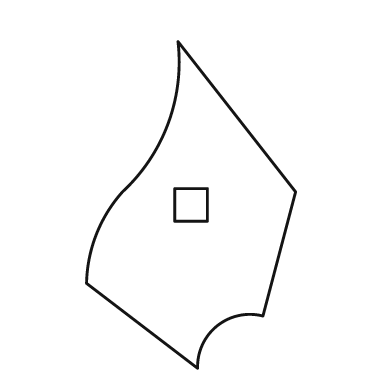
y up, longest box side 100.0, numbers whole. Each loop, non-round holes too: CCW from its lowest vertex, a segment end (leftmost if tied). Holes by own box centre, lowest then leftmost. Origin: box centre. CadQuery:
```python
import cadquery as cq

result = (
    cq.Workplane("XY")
    .moveTo(2.0, -50.0)
    .threePointArc((8.0, -37.0), (22.0, -34.0))
    .lineTo(32.0, 4.0)
    .lineTo(-4.0, 50.0)
    .threePointArc((-7.0, 25.0), (-21.0, 4.0))
    .threePointArc((-29.0, -9.0), (-32.0, -24.0))
    .close()
    .moveTo(-5.0, -5.0)
    .lineTo(5.0, -5.0)
    .lineTo(5.0, 5.0)
    .lineTo(-5.0, 5.0)
    .close()
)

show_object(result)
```